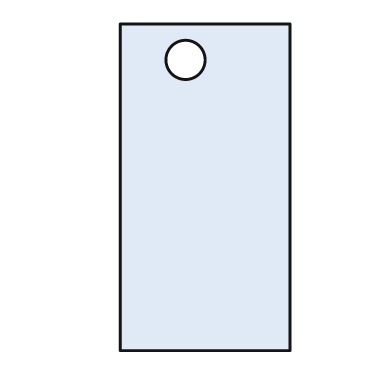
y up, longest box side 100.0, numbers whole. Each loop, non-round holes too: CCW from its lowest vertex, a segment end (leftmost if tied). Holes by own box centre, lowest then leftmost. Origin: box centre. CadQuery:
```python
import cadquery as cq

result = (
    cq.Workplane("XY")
    .moveTo(-26.0, -50.0)
    .lineTo(26.0, -50.0)
    .lineTo(26.0, 50.0)
    .lineTo(-26.0, 50.0)
    .close()
    .moveTo(-6.0, 39.0)
    .circle(6.0)
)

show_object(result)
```